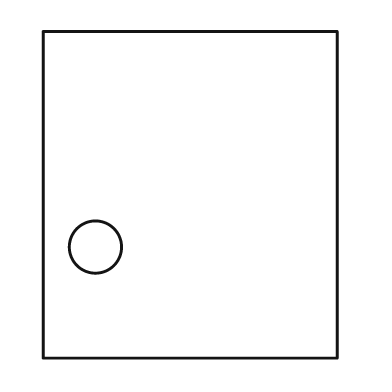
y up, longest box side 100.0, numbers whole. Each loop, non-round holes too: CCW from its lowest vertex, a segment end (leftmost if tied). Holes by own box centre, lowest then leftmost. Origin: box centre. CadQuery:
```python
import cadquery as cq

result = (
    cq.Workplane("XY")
    .moveTo(-45.0, -50.0)
    .lineTo(45.0, -50.0)
    .lineTo(45.0, 50.0)
    .lineTo(-45.0, 50.0)
    .close()
    .moveTo(-29.0, -16.0)
    .circle(8.0)
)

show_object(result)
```